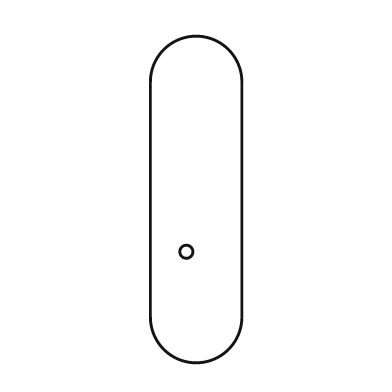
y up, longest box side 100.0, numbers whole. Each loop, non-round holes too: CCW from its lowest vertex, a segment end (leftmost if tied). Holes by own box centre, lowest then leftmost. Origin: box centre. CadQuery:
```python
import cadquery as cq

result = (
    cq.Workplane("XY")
    .moveTo(-14.0, -36.0)
    .threePointArc((0.0, -50.0), (14.0, -36.0))
    .lineTo(14.0, 36.0)
    .threePointArc((0.0, 50.0), (-14.0, 36.0))
    .close()
    .moveTo(-3.0, -16.0)
    .circle(2.0)
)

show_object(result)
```